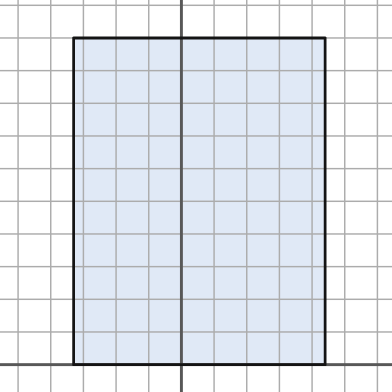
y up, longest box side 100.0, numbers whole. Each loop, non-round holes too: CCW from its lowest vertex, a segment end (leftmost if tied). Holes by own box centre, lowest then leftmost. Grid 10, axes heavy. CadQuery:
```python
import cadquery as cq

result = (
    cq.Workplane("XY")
    .moveTo(-33.0, 0.0)
    .lineTo(44.0, 0.0)
    .lineTo(44.0, 100.0)
    .lineTo(-33.0, 100.0)
    .close()
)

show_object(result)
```